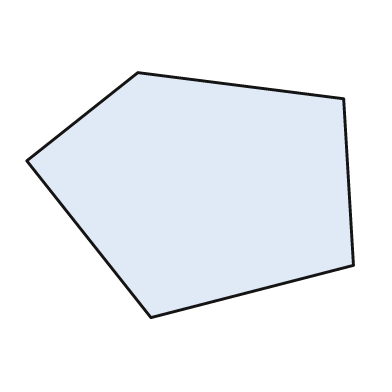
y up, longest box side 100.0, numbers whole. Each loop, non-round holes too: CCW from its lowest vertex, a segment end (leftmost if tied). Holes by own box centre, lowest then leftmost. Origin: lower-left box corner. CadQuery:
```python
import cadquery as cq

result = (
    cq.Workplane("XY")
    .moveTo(38.0, 0.0)
    .lineTo(100.0, 16.0)
    .lineTo(97.0, 67.0)
    .lineTo(34.0, 75.0)
    .lineTo(0.0, 48.0)
    .close()
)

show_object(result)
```